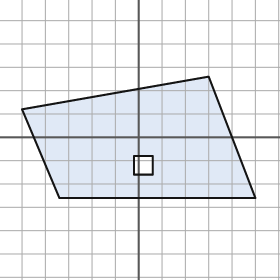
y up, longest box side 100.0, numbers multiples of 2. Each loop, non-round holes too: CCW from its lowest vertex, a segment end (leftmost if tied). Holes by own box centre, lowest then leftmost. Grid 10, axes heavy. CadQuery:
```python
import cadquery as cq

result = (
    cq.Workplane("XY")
    .moveTo(-34.0, -26.0)
    .lineTo(50.0, -26.0)
    .lineTo(30.0, 26.0)
    .lineTo(-50.0, 12.0)
    .close()
    .moveTo(-2.0, -16.0)
    .lineTo(6.0, -16.0)
    .lineTo(6.0, -8.0)
    .lineTo(-2.0, -8.0)
    .close()
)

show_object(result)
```